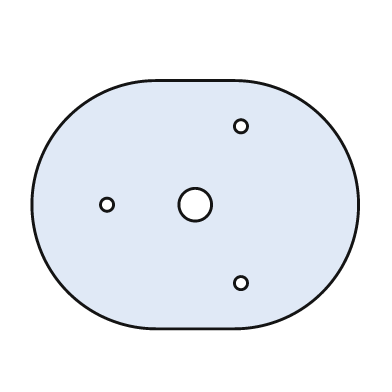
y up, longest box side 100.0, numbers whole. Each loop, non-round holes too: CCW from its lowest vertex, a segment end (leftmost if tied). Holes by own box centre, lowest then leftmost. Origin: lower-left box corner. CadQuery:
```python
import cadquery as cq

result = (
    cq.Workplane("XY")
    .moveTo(38.0, 0.0)
    .lineTo(62.0, 0.0)
    .threePointArc((100.0, 38.0), (62.0, 76.0))
    .lineTo(38.0, 76.0)
    .threePointArc((0.0, 38.0), (38.0, 0.0))
    .close()
    .moveTo(64.0, 14.0)
    .circle(2.0)
    .moveTo(23.0, 38.0)
    .circle(2.0)
    .moveTo(50.0, 38.0)
    .circle(5.0)
    .moveTo(64.0, 62.0)
    .circle(2.0)
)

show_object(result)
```